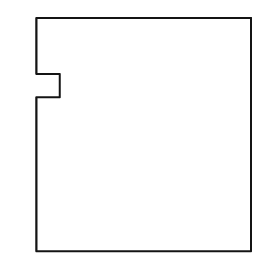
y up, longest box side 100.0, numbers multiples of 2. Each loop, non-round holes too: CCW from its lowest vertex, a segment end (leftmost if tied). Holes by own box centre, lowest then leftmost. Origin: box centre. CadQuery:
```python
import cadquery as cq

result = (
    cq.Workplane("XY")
    .moveTo(-46.0, -50.0)
    .lineTo(46.0, -50.0)
    .lineTo(46.0, 50.0)
    .lineTo(-46.0, 50.0)
    .lineTo(-46.0, 26.0)
    .lineTo(-36.0, 26.0)
    .lineTo(-36.0, 16.0)
    .lineTo(-46.0, 16.0)
    .close()
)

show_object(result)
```